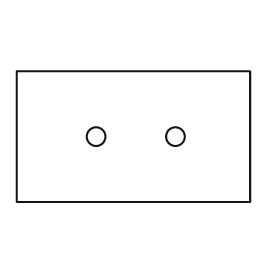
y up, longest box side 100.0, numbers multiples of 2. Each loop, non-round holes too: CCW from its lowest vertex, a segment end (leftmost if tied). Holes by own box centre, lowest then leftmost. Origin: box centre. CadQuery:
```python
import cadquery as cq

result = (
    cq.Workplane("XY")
    .moveTo(-50.0, -28.0)
    .lineTo(50.0, -28.0)
    .lineTo(50.0, 28.0)
    .lineTo(-50.0, 28.0)
    .close()
    .moveTo(-16.0, 0.0)
    .circle(4.0)
    .moveTo(18.0, 0.0)
    .circle(4.0)
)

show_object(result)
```